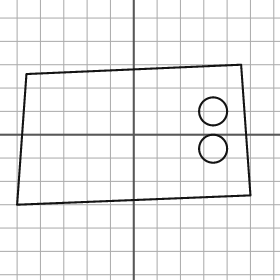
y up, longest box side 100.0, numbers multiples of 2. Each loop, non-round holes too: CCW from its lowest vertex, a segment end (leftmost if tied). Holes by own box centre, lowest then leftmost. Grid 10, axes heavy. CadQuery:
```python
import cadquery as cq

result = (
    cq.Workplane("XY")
    .moveTo(-50.0, -30.0)
    .lineTo(50.0, -26.0)
    .lineTo(46.0, 30.0)
    .lineTo(-46.0, 26.0)
    .close()
    .moveTo(34.0, -6.0)
    .circle(6.0)
    .moveTo(34.0, 10.0)
    .circle(6.0)
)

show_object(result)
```